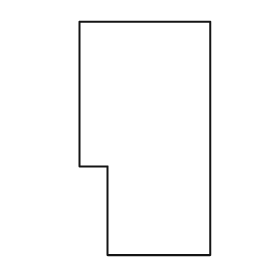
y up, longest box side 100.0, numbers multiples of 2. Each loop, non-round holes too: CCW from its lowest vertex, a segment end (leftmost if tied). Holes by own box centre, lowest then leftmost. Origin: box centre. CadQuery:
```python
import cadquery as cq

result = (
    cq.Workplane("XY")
    .moveTo(-16.0, -50.0)
    .lineTo(28.0, -50.0)
    .lineTo(28.0, 50.0)
    .lineTo(-28.0, 50.0)
    .lineTo(-28.0, -12.0)
    .lineTo(-16.0, -12.0)
    .close()
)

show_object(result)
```